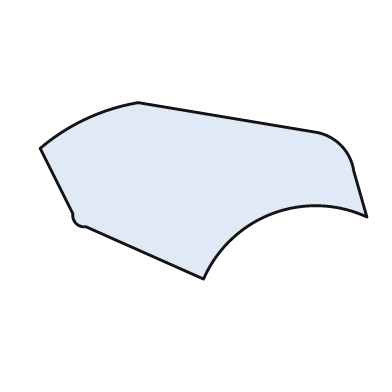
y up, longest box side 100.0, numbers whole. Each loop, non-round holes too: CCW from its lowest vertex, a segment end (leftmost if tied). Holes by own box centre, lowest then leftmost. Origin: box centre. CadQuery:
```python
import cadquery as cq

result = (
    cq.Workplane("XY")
    .moveTo(0.0, -27.0)
    .threePointArc((21.0, -7.0), (50.0, -8.0))
    .lineTo(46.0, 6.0)
    .threePointArc((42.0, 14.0), (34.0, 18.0))
    .lineTo(-20.0, 27.0)
    .threePointArc((-36.0, 22.0), (-50.0, 13.0))
    .lineTo(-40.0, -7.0)
    .threePointArc((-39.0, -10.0), (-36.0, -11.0))
    .close()
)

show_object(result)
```